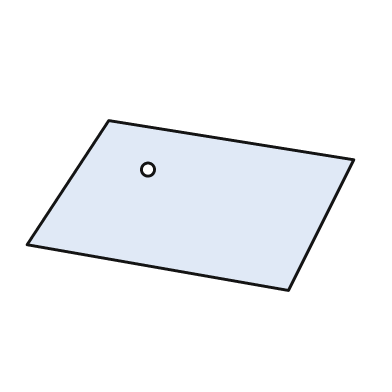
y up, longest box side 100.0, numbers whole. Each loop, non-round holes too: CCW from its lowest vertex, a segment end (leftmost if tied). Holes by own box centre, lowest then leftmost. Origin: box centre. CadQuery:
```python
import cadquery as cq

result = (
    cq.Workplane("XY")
    .moveTo(30.0, -26.0)
    .lineTo(50.0, 14.0)
    .lineTo(-25.0, 26.0)
    .lineTo(-50.0, -12.0)
    .close()
    .moveTo(-13.0, 11.0)
    .circle(2.0)
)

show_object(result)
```